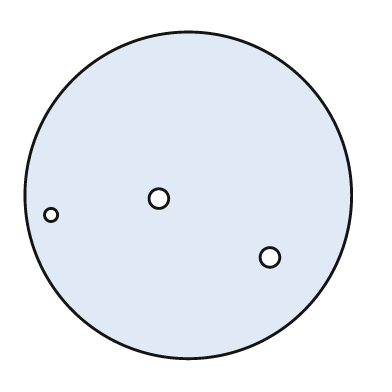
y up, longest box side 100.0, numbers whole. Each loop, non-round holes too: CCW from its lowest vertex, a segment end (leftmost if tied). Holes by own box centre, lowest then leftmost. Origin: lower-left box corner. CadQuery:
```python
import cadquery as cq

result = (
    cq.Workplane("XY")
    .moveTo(50.0, 50.0)
    .circle(50.0)
    .moveTo(75.0, 31.0)
    .circle(3.0)
    .moveTo(8.0, 44.0)
    .circle(2.0)
    .moveTo(41.0, 49.0)
    .circle(3.0)
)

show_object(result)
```